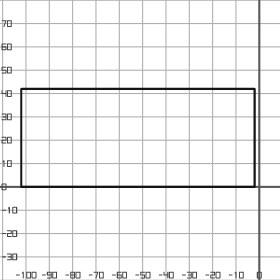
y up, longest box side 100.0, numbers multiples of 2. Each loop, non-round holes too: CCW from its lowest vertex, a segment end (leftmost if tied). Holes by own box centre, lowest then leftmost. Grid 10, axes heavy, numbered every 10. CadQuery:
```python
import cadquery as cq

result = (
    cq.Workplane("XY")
    .moveTo(-102.0, 0.0)
    .lineTo(-2.0, 0.0)
    .lineTo(-2.0, 42.0)
    .lineTo(-102.0, 42.0)
    .close()
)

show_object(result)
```